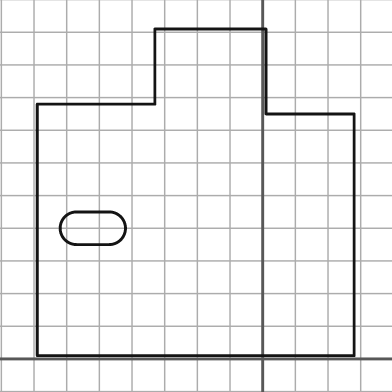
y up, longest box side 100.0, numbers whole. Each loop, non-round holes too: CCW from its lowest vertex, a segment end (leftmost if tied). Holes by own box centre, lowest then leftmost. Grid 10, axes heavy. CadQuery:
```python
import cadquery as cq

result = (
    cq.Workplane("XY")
    .moveTo(-69.0, 1.0)
    .lineTo(28.0, 1.0)
    .lineTo(28.0, 75.0)
    .lineTo(1.0, 75.0)
    .lineTo(1.0, 101.0)
    .lineTo(-33.0, 101.0)
    .lineTo(-33.0, 78.0)
    .lineTo(-69.0, 78.0)
    .close()
    .moveTo(-57.0, 35.0)
    .lineTo(-47.0, 35.0)
    .threePointArc((-42.0, 40.0), (-47.0, 45.0))
    .lineTo(-57.0, 45.0)
    .threePointArc((-62.0, 40.0), (-57.0, 35.0))
    .close()
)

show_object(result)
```